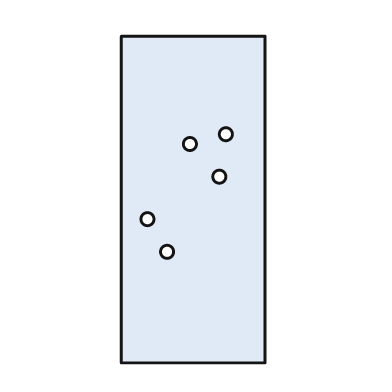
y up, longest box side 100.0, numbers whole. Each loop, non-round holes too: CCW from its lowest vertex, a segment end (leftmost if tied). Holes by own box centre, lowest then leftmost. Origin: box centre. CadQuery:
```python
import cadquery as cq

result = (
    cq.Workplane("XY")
    .moveTo(-22.0, -50.0)
    .lineTo(22.0, -50.0)
    .lineTo(22.0, 50.0)
    .lineTo(-22.0, 50.0)
    .close()
    .moveTo(-8.0, -16.0)
    .circle(2.0)
    .moveTo(-14.0, -6.0)
    .circle(2.0)
    .moveTo(8.0, 7.0)
    .circle(2.0)
    .moveTo(-1.0, 17.0)
    .circle(2.0)
    .moveTo(10.0, 20.0)
    .circle(2.0)
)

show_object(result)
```